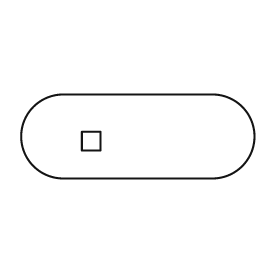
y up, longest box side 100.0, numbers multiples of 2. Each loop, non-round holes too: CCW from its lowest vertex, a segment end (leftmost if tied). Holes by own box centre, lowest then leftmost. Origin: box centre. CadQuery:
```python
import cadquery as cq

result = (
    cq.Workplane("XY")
    .moveTo(-32.0, -18.0)
    .lineTo(32.0, -18.0)
    .threePointArc((50.0, 0.0), (32.0, 18.0))
    .lineTo(-32.0, 18.0)
    .threePointArc((-50.0, 0.0), (-32.0, -18.0))
    .close()
    .moveTo(-24.0, -6.0)
    .lineTo(-16.0, -6.0)
    .lineTo(-16.0, 2.0)
    .lineTo(-24.0, 2.0)
    .close()
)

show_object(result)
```